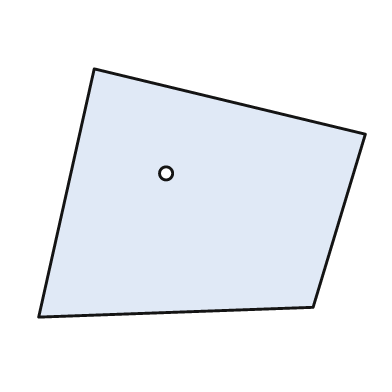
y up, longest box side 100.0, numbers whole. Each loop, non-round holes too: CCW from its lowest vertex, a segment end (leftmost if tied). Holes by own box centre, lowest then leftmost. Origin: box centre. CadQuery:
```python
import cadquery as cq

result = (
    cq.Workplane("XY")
    .moveTo(-50.0, -38.0)
    .lineTo(34.0, -35.0)
    .lineTo(50.0, 18.0)
    .lineTo(-33.0, 38.0)
    .close()
    .moveTo(-11.0, 6.0)
    .circle(2.0)
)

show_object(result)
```